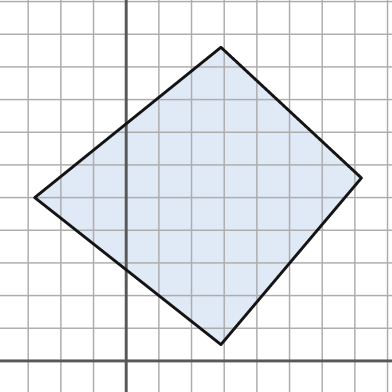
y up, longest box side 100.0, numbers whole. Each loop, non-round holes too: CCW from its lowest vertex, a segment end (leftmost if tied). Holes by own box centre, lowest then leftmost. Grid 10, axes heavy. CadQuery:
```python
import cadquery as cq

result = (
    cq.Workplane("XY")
    .moveTo(29.0, 5.0)
    .lineTo(72.0, 56.0)
    .lineTo(29.0, 96.0)
    .lineTo(-28.0, 50.0)
    .close()
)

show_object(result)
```